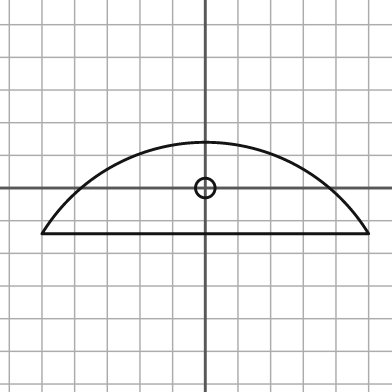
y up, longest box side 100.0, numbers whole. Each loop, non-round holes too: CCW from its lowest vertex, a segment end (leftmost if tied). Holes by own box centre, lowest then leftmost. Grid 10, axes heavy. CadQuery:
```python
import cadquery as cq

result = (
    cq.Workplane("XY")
    .moveTo(-50.0, -14.0)
    .lineTo(50.0, -14.0)
    .threePointArc((0.0, 14.0), (-50.0, -14.0))
    .close()
    .moveTo(0.0, 0.0)
    .circle(3.0)
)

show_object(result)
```